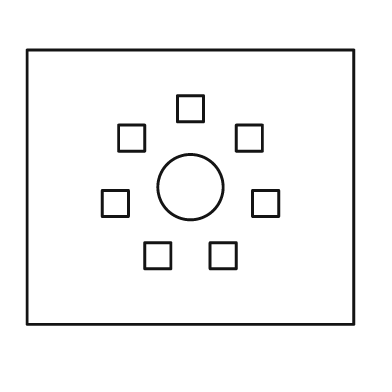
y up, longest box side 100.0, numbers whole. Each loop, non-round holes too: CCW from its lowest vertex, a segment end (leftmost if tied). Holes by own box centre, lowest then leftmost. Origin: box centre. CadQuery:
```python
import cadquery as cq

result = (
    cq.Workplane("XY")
    .moveTo(-50.0, -42.0)
    .lineTo(50.0, -42.0)
    .lineTo(50.0, 42.0)
    .lineTo(-50.0, 42.0)
    .close()
    .moveTo(-14.0, -25.0)
    .lineTo(-6.0, -25.0)
    .lineTo(-6.0, -17.0)
    .lineTo(-14.0, -17.0)
    .close()
    .moveTo(6.0, -25.0)
    .lineTo(14.0, -25.0)
    .lineTo(14.0, -17.0)
    .lineTo(6.0, -17.0)
    .close()
    .moveTo(-27.0, -9.0)
    .lineTo(-19.0, -9.0)
    .lineTo(-19.0, -1.0)
    .lineTo(-27.0, -1.0)
    .close()
    .moveTo(19.0, -9.0)
    .lineTo(27.0, -9.0)
    .lineTo(27.0, -1.0)
    .lineTo(19.0, -1.0)
    .close()
    .moveTo(0.0, 0.0)
    .circle(10.0)
    .moveTo(-22.0, 11.0)
    .lineTo(-14.0, 11.0)
    .lineTo(-14.0, 19.0)
    .lineTo(-22.0, 19.0)
    .close()
    .moveTo(14.0, 11.0)
    .lineTo(22.0, 11.0)
    .lineTo(22.0, 19.0)
    .lineTo(14.0, 19.0)
    .close()
    .moveTo(-4.0, 20.0)
    .lineTo(4.0, 20.0)
    .lineTo(4.0, 28.0)
    .lineTo(-4.0, 28.0)
    .close()
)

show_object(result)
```